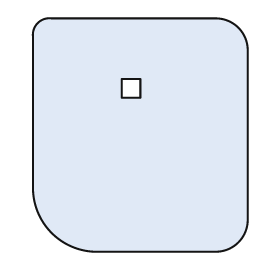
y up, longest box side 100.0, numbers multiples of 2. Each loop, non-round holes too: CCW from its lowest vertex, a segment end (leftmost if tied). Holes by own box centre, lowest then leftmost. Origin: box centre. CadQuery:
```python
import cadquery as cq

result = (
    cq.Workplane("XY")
    .moveTo(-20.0, -50.0)
    .lineTo(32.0, -50.0)
    .threePointArc((42.0, -46.0), (46.0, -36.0))
    .lineTo(46.0, 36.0)
    .threePointArc((42.0, 46.0), (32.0, 50.0))
    .lineTo(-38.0, 50.0)
    .threePointArc((-44.0, 48.0), (-46.0, 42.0))
    .lineTo(-46.0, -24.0)
    .threePointArc((-38.0, -42.0), (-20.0, -50.0))
    .close()
    .moveTo(-8.0, 16.0)
    .lineTo(0.0, 16.0)
    .lineTo(0.0, 24.0)
    .lineTo(-8.0, 24.0)
    .close()
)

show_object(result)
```